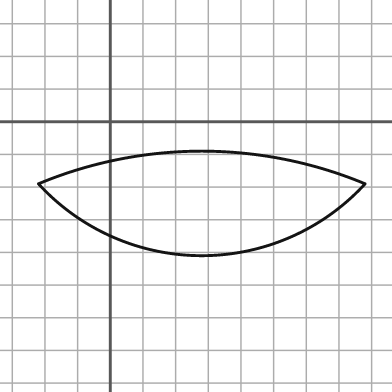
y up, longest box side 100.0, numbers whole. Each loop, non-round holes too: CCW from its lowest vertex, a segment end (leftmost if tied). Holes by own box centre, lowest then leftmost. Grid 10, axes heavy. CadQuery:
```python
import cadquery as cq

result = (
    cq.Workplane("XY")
    .moveTo(-22.0, -19.0)
    .threePointArc((28.0, -41.0), (78.0, -19.0))
    .threePointArc((28.0, -9.0), (-22.0, -19.0))
    .close()
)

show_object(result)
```